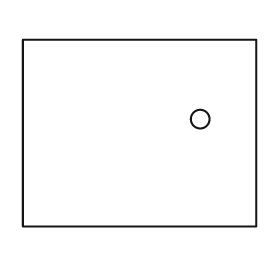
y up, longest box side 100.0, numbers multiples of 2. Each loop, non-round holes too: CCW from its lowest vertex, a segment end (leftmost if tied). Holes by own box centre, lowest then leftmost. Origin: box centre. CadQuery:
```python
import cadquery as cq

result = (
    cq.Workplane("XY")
    .moveTo(-50.0, -40.0)
    .lineTo(50.0, -40.0)
    .lineTo(50.0, 40.0)
    .lineTo(-50.0, 40.0)
    .close()
    .moveTo(26.0, 6.0)
    .circle(4.0)
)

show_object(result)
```